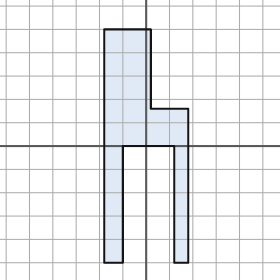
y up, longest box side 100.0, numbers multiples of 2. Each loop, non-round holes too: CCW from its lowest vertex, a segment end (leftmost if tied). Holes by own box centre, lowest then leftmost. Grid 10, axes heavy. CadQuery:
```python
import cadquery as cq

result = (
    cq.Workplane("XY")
    .moveTo(-18.0, -50.0)
    .lineTo(-10.0, -50.0)
    .lineTo(-10.0, 0.0)
    .lineTo(12.0, 0.0)
    .lineTo(12.0, -50.0)
    .lineTo(18.0, -50.0)
    .lineTo(18.0, 16.0)
    .lineTo(2.0, 16.0)
    .lineTo(2.0, 50.0)
    .lineTo(-18.0, 50.0)
    .close()
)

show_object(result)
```